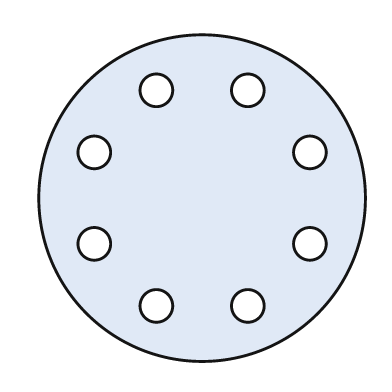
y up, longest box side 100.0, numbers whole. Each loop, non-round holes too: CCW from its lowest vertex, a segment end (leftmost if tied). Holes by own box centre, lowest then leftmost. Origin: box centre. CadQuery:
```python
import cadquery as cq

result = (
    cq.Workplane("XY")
    .moveTo(0.0, 0.0)
    .circle(50.0)
    .moveTo(-14.0, -33.0)
    .circle(5.0)
    .moveTo(14.0, -33.0)
    .circle(5.0)
    .moveTo(-33.0, -14.0)
    .circle(5.0)
    .moveTo(33.0, -14.0)
    .circle(5.0)
    .moveTo(-33.0, 14.0)
    .circle(5.0)
    .moveTo(33.0, 14.0)
    .circle(5.0)
    .moveTo(-14.0, 33.0)
    .circle(5.0)
    .moveTo(14.0, 33.0)
    .circle(5.0)
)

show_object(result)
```